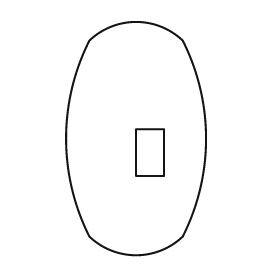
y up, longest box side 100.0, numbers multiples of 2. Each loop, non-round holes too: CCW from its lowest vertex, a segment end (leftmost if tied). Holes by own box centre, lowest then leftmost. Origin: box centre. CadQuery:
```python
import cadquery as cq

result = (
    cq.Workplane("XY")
    .moveTo(-20.0, -42.0)
    .threePointArc((0.0, -50.0), (20.0, -42.0))
    .threePointArc((30.0, 0.0), (20.0, 42.0))
    .threePointArc((0.0, 50.0), (-20.0, 42.0))
    .threePointArc((-30.0, 0.0), (-20.0, -42.0))
    .close()
    .moveTo(0.0, -16.0)
    .lineTo(12.0, -16.0)
    .lineTo(12.0, 4.0)
    .lineTo(0.0, 4.0)
    .close()
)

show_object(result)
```